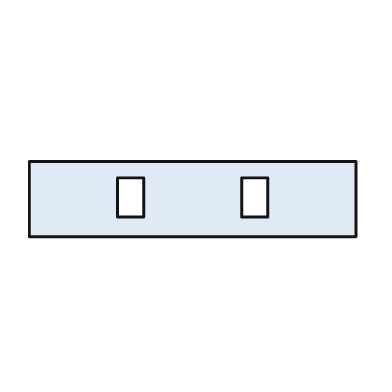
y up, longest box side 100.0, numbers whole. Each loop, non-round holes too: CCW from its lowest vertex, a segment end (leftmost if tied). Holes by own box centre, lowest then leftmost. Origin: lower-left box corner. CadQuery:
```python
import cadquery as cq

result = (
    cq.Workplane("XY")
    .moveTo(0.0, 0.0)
    .lineTo(100.0, 0.0)
    .lineTo(100.0, 23.0)
    .lineTo(0.0, 23.0)
    .close()
    .moveTo(27.0, 6.0)
    .lineTo(35.0, 6.0)
    .lineTo(35.0, 18.0)
    .lineTo(27.0, 18.0)
    .close()
    .moveTo(65.0, 6.0)
    .lineTo(73.0, 6.0)
    .lineTo(73.0, 18.0)
    .lineTo(65.0, 18.0)
    .close()
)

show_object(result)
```